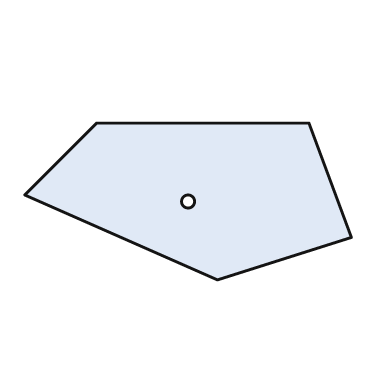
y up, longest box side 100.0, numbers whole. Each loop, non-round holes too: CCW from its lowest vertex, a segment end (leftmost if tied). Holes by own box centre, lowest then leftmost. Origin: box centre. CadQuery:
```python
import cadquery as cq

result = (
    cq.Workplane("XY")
    .moveTo(9.0, -24.0)
    .lineTo(50.0, -11.0)
    .lineTo(37.0, 24.0)
    .lineTo(-28.0, 24.0)
    .lineTo(-50.0, 2.0)
    .close()
    .moveTo(0.0, 0.0)
    .circle(2.0)
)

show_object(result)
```